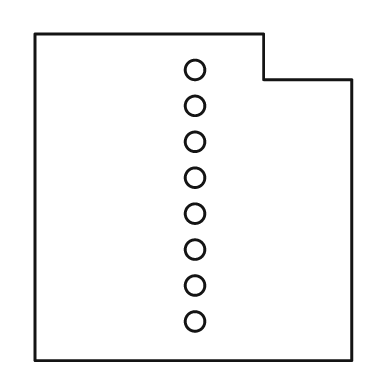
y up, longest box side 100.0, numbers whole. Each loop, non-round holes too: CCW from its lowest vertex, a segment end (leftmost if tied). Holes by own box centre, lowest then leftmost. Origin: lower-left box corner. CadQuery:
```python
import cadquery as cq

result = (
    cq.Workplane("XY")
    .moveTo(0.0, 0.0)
    .lineTo(97.0, 0.0)
    .lineTo(97.0, 86.0)
    .lineTo(70.0, 86.0)
    .lineTo(70.0, 100.0)
    .lineTo(0.0, 100.0)
    .close()
    .moveTo(49.0, 12.0)
    .circle(3.0)
    .moveTo(49.0, 23.0)
    .circle(3.0)
    .moveTo(49.0, 34.0)
    .circle(3.0)
    .moveTo(49.0, 45.0)
    .circle(3.0)
    .moveTo(49.0, 56.0)
    .circle(3.0)
    .moveTo(49.0, 67.0)
    .circle(3.0)
    .moveTo(49.0, 78.0)
    .circle(3.0)
    .moveTo(49.0, 89.0)
    .circle(3.0)
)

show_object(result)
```